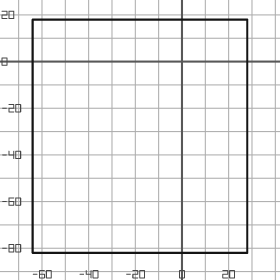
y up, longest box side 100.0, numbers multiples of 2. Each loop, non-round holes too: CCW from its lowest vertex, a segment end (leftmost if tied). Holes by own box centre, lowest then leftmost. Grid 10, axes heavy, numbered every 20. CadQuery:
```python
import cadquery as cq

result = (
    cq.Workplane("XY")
    .moveTo(-64.0, -82.0)
    .lineTo(28.0, -82.0)
    .lineTo(28.0, 18.0)
    .lineTo(-64.0, 18.0)
    .close()
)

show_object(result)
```